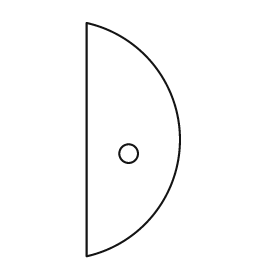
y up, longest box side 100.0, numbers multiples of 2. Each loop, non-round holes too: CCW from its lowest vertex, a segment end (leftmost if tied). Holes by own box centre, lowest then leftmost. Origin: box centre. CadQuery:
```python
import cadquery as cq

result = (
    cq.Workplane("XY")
    .moveTo(-20.0, -50.0)
    .threePointArc((20.0, 0.0), (-20.0, 50.0))
    .close()
    .moveTo(-2.0, -6.0)
    .circle(4.0)
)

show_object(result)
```